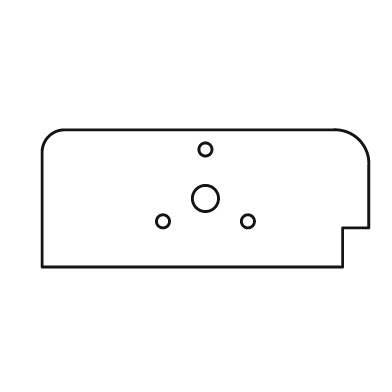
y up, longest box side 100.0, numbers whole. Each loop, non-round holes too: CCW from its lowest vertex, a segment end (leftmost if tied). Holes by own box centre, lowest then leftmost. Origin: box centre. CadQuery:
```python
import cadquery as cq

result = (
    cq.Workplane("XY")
    .moveTo(-50.0, -21.0)
    .lineTo(42.0, -21.0)
    .lineTo(42.0, -9.0)
    .lineTo(50.0, -9.0)
    .lineTo(50.0, 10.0)
    .threePointArc((47.0, 18.0), (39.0, 21.0))
    .lineTo(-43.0, 21.0)
    .threePointArc((-48.0, 19.0), (-50.0, 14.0))
    .close()
    .moveTo(-13.0, -7.0)
    .circle(2.0)
    .moveTo(13.0, -7.0)
    .circle(2.0)
    .moveTo(0.0, 0.0)
    .circle(4.0)
    .moveTo(0.0, 15.0)
    .circle(2.0)
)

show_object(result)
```